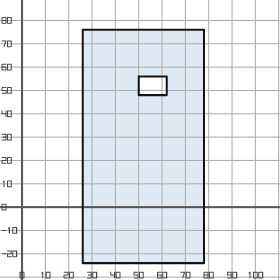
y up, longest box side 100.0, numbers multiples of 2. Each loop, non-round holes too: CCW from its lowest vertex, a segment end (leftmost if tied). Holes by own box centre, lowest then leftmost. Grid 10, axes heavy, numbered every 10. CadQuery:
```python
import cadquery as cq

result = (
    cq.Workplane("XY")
    .moveTo(26.0, -24.0)
    .lineTo(78.0, -24.0)
    .lineTo(78.0, 76.0)
    .lineTo(26.0, 76.0)
    .close()
    .moveTo(50.0, 48.0)
    .lineTo(62.0, 48.0)
    .lineTo(62.0, 56.0)
    .lineTo(50.0, 56.0)
    .close()
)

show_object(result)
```